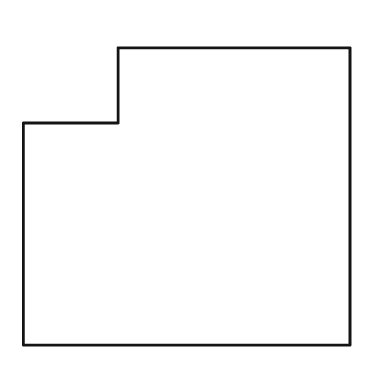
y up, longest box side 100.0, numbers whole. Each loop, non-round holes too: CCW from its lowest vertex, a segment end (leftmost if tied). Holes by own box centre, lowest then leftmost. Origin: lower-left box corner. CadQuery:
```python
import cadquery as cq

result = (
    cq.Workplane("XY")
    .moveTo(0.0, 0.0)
    .lineTo(100.0, 0.0)
    .lineTo(100.0, 91.0)
    .lineTo(29.0, 91.0)
    .lineTo(29.0, 68.0)
    .lineTo(0.0, 68.0)
    .close()
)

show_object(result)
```